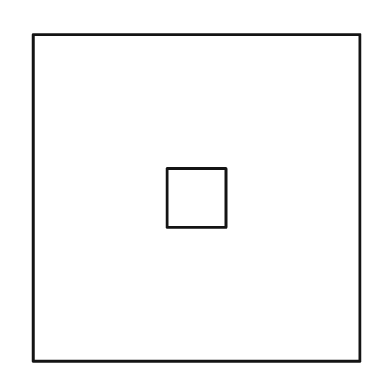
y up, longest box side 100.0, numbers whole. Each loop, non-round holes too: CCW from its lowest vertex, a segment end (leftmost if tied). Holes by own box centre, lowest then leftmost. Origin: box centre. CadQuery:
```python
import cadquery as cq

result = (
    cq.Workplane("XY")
    .moveTo(-50.0, -50.0)
    .lineTo(50.0, -50.0)
    .lineTo(50.0, 50.0)
    .lineTo(-50.0, 50.0)
    .close()
    .moveTo(-9.0, -9.0)
    .lineTo(9.0, -9.0)
    .lineTo(9.0, 9.0)
    .lineTo(-9.0, 9.0)
    .close()
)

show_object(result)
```